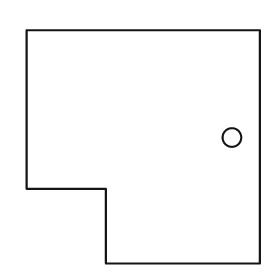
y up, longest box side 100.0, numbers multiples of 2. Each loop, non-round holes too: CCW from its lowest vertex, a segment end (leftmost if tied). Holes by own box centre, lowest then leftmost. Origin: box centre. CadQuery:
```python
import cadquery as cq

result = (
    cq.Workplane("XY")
    .moveTo(-16.0, -50.0)
    .lineTo(50.0, -50.0)
    .lineTo(50.0, 50.0)
    .lineTo(-50.0, 50.0)
    .lineTo(-50.0, -18.0)
    .lineTo(-16.0, -18.0)
    .close()
    .moveTo(38.0, 4.0)
    .circle(4.0)
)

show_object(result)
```